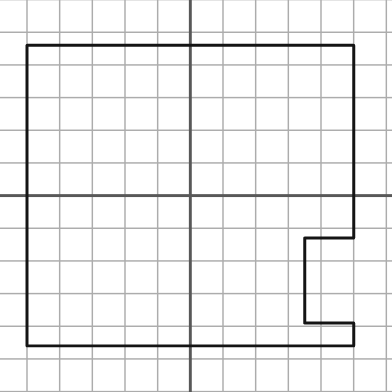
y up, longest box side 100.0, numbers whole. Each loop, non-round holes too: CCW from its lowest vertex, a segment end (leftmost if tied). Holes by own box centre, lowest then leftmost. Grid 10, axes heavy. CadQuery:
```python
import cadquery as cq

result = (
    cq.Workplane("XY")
    .moveTo(-50.0, -46.0)
    .lineTo(50.0, -46.0)
    .lineTo(50.0, -39.0)
    .lineTo(35.0, -39.0)
    .lineTo(35.0, -13.0)
    .lineTo(50.0, -13.0)
    .lineTo(50.0, 46.0)
    .lineTo(-50.0, 46.0)
    .close()
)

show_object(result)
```